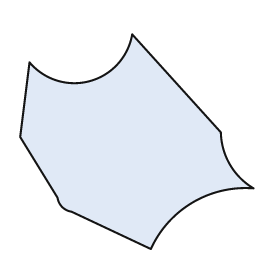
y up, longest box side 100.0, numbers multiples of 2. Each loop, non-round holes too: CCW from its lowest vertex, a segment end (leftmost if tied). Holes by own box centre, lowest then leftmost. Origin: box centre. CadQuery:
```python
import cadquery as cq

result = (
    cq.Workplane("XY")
    .moveTo(6.0, -46.0)
    .threePointArc((24.0, -26.0), (50.0, -20.0))
    .threePointArc((40.0, -10.0), (36.0, 4.0))
    .lineTo(-2.0, 46.0)
    .threePointArc((-20.0, 26.0), (-46.0, 34.0))
    .lineTo(-50.0, 2.0)
    .lineTo(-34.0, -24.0)
    .threePointArc((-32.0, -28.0), (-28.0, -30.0))
    .close()
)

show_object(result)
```